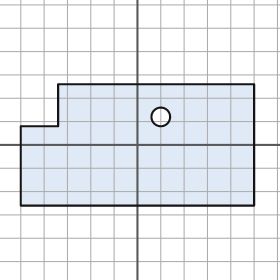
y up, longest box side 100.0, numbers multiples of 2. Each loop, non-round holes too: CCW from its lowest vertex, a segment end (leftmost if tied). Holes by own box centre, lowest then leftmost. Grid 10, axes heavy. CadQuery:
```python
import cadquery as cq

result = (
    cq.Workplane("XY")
    .moveTo(-50.0, -26.0)
    .lineTo(50.0, -26.0)
    .lineTo(50.0, 26.0)
    .lineTo(-34.0, 26.0)
    .lineTo(-34.0, 8.0)
    .lineTo(-50.0, 8.0)
    .close()
    .moveTo(10.0, 12.0)
    .circle(4.0)
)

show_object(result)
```